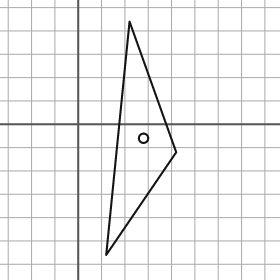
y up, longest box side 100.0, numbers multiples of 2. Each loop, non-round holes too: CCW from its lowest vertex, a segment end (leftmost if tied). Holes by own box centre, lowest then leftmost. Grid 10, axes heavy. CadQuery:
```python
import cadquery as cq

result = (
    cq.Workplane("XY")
    .moveTo(12.0, -56.0)
    .lineTo(42.0, -12.0)
    .lineTo(22.0, 44.0)
    .close()
    .moveTo(28.0, -6.0)
    .circle(2.0)
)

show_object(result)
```